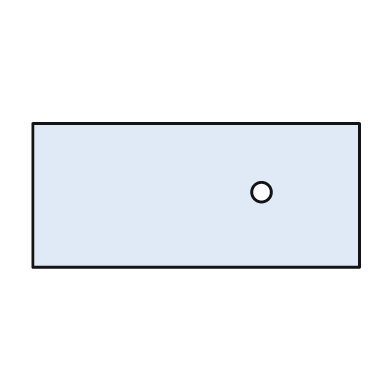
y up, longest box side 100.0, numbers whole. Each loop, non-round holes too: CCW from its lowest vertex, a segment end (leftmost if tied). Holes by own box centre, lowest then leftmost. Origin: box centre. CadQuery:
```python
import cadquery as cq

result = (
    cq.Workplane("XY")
    .moveTo(-50.0, -22.0)
    .lineTo(50.0, -22.0)
    .lineTo(50.0, 22.0)
    .lineTo(-50.0, 22.0)
    .close()
    .moveTo(20.0, 1.0)
    .circle(3.0)
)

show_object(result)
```